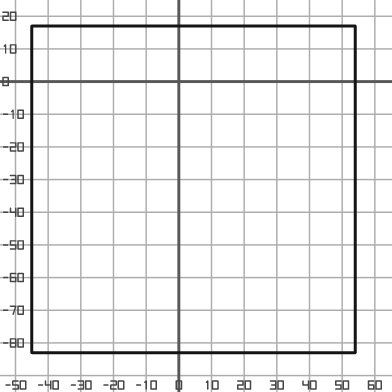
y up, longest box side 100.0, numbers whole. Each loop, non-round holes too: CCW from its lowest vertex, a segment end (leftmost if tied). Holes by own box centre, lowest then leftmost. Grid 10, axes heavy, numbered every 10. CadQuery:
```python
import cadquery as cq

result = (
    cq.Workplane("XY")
    .moveTo(-45.0, -83.0)
    .lineTo(54.0, -83.0)
    .lineTo(54.0, 17.0)
    .lineTo(-45.0, 17.0)
    .close()
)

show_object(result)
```